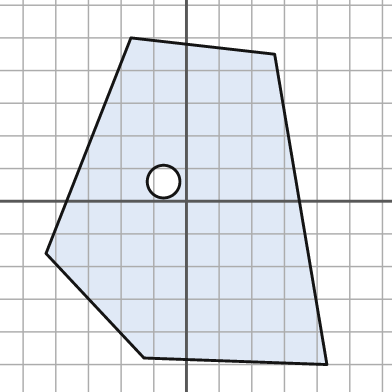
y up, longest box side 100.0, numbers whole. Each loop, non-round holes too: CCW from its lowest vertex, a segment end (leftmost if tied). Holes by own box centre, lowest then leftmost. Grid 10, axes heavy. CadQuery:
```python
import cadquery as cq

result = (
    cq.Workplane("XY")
    .moveTo(43.0, -50.0)
    .lineTo(27.0, 45.0)
    .lineTo(-17.0, 50.0)
    .lineTo(-43.0, -16.0)
    .lineTo(-13.0, -48.0)
    .close()
    .moveTo(-7.0, 6.0)
    .circle(5.0)
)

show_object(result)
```